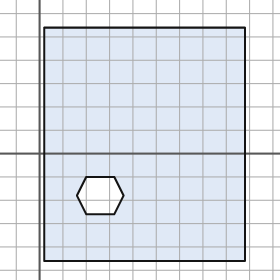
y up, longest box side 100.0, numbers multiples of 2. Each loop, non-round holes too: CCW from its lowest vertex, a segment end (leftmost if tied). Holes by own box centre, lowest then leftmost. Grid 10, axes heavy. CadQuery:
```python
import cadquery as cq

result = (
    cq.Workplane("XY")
    .moveTo(2.0, -46.0)
    .lineTo(88.0, -46.0)
    .lineTo(88.0, 54.0)
    .lineTo(2.0, 54.0)
    .close()
    .moveTo(20.0, -26.0)
    .lineTo(32.0, -26.0)
    .lineTo(36.0, -18.0)
    .lineTo(32.0, -10.0)
    .lineTo(20.0, -10.0)
    .lineTo(16.0, -18.0)
    .close()
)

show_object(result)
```